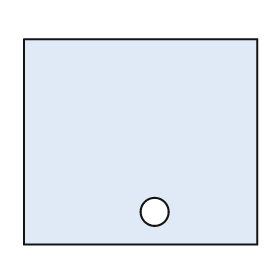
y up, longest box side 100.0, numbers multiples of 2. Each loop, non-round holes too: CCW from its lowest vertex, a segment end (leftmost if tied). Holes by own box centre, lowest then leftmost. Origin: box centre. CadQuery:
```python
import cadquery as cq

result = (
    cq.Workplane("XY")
    .moveTo(-50.0, -44.0)
    .lineTo(50.0, -44.0)
    .lineTo(50.0, 44.0)
    .lineTo(-50.0, 44.0)
    .close()
    .moveTo(6.0, -30.0)
    .circle(6.0)
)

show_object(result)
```